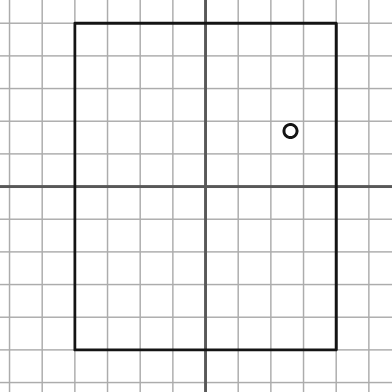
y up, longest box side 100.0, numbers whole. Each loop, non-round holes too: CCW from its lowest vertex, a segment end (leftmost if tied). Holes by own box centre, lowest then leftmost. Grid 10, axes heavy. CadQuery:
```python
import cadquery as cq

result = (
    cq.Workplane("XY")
    .moveTo(-40.0, -50.0)
    .lineTo(40.0, -50.0)
    .lineTo(40.0, 50.0)
    .lineTo(-40.0, 50.0)
    .close()
    .moveTo(26.0, 17.0)
    .circle(2.0)
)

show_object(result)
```